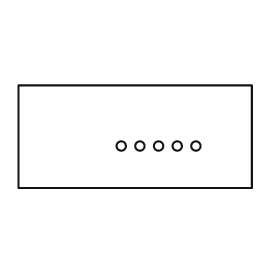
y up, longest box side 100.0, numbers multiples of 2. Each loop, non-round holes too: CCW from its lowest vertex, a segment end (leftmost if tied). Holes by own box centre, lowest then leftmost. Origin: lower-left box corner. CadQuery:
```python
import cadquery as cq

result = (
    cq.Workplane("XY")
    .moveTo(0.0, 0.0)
    .lineTo(100.0, 0.0)
    .lineTo(100.0, 44.0)
    .lineTo(0.0, 44.0)
    .close()
    .moveTo(44.0, 18.0)
    .circle(2.0)
    .moveTo(52.0, 18.0)
    .circle(2.0)
    .moveTo(60.0, 18.0)
    .circle(2.0)
    .moveTo(68.0, 18.0)
    .circle(2.0)
    .moveTo(76.0, 18.0)
    .circle(2.0)
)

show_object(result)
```